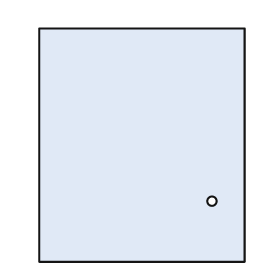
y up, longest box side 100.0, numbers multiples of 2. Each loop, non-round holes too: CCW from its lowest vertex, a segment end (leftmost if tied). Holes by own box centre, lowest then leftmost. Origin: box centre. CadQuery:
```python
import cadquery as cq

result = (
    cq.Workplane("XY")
    .moveTo(-44.0, -50.0)
    .lineTo(44.0, -50.0)
    .lineTo(44.0, 50.0)
    .lineTo(-44.0, 50.0)
    .close()
    .moveTo(30.0, -24.0)
    .circle(2.0)
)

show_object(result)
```